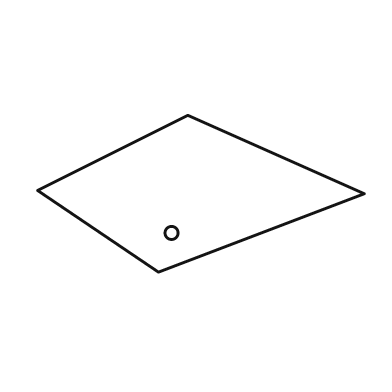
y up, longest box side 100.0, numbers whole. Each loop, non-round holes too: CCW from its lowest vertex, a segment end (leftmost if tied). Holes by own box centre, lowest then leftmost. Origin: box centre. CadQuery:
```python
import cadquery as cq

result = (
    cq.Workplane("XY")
    .moveTo(-13.0, -24.0)
    .lineTo(50.0, 0.0)
    .lineTo(-4.0, 24.0)
    .lineTo(-50.0, 1.0)
    .close()
    .moveTo(-9.0, -12.0)
    .circle(2.0)
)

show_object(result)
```